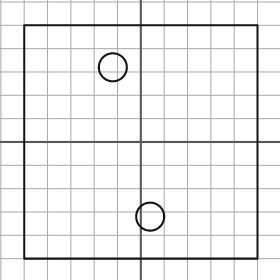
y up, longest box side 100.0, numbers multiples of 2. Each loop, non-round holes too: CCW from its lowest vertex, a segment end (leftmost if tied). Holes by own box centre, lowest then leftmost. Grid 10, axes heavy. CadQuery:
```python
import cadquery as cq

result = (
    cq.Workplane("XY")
    .moveTo(-50.0, -50.0)
    .lineTo(50.0, -50.0)
    .lineTo(50.0, 50.0)
    .lineTo(-50.0, 50.0)
    .close()
    .moveTo(4.0, -32.0)
    .circle(6.0)
    .moveTo(-12.0, 32.0)
    .circle(6.0)
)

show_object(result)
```